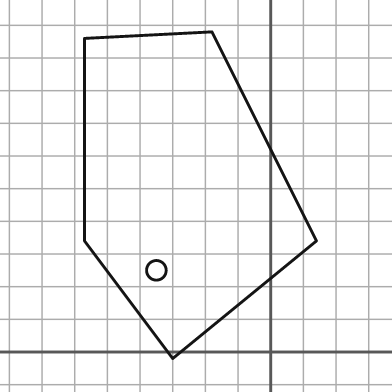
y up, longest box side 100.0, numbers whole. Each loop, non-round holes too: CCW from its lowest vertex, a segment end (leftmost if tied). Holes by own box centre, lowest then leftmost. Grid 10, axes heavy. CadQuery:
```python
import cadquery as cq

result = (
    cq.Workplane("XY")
    .moveTo(-30.0, -2.0)
    .lineTo(14.0, 34.0)
    .lineTo(-18.0, 98.0)
    .lineTo(-57.0, 96.0)
    .lineTo(-57.0, 34.0)
    .close()
    .moveTo(-35.0, 25.0)
    .circle(3.0)
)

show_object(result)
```